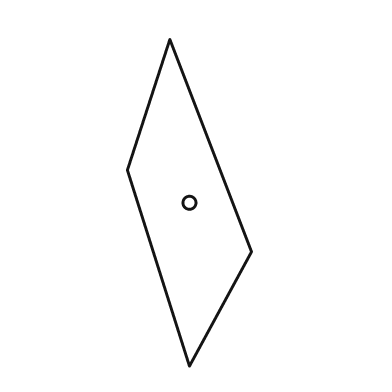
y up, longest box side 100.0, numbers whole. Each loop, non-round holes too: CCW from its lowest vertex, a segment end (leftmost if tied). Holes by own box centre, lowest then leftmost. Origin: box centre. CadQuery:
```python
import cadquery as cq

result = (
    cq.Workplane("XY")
    .moveTo(0.0, -50.0)
    .lineTo(19.0, -15.0)
    .lineTo(-6.0, 50.0)
    .lineTo(-19.0, 10.0)
    .close()
    .moveTo(0.0, 0.0)
    .circle(2.0)
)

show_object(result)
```